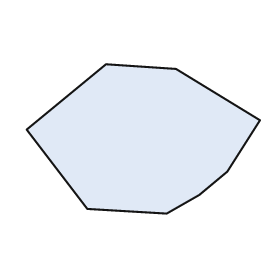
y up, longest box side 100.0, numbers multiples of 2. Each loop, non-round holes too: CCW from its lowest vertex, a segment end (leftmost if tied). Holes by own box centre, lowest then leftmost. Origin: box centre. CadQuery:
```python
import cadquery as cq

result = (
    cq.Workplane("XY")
    .moveTo(10.0, -32.0)
    .lineTo(24.0, -24.0)
    .lineTo(36.0, -14.0)
    .lineTo(50.0, 8.0)
    .lineTo(14.0, 30.0)
    .lineTo(-16.0, 32.0)
    .lineTo(-50.0, 4.0)
    .lineTo(-24.0, -30.0)
    .close()
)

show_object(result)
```